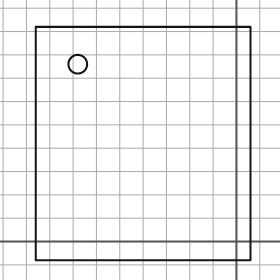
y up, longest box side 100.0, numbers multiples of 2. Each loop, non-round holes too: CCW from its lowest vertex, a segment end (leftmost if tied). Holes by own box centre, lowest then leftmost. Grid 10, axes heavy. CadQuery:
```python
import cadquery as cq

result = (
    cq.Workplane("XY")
    .moveTo(-86.0, -8.0)
    .lineTo(6.0, -8.0)
    .lineTo(6.0, 92.0)
    .lineTo(-86.0, 92.0)
    .close()
    .moveTo(-68.0, 76.0)
    .circle(4.0)
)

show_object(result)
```